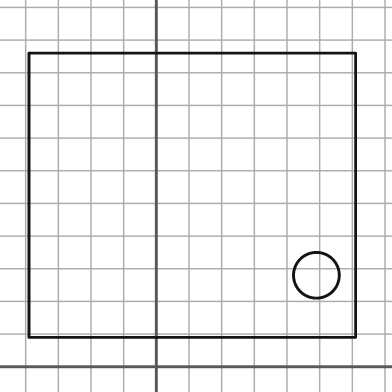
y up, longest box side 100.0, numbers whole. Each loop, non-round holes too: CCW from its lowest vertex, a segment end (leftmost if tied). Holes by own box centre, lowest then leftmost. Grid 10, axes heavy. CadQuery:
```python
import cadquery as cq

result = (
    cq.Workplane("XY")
    .moveTo(-39.0, 9.0)
    .lineTo(61.0, 9.0)
    .lineTo(61.0, 96.0)
    .lineTo(-39.0, 96.0)
    .close()
    .moveTo(49.0, 28.0)
    .circle(7.0)
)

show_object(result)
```